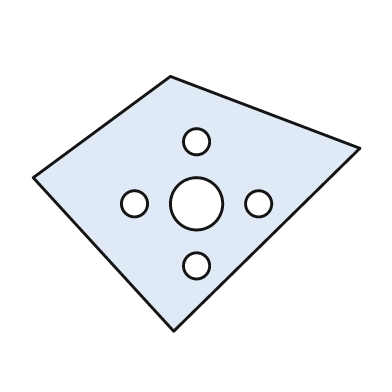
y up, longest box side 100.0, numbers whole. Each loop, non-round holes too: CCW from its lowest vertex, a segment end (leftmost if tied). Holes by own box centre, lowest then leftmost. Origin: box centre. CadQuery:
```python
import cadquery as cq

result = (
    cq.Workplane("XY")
    .moveTo(-7.0, -39.0)
    .lineTo(50.0, 17.0)
    .lineTo(-8.0, 39.0)
    .lineTo(-50.0, 8.0)
    .close()
    .moveTo(0.0, -19.0)
    .circle(4.0)
    .moveTo(-19.0, 0.0)
    .circle(4.0)
    .moveTo(0.0, 0.0)
    .circle(8.0)
    .moveTo(19.0, 0.0)
    .circle(4.0)
    .moveTo(0.0, 19.0)
    .circle(4.0)
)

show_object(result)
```